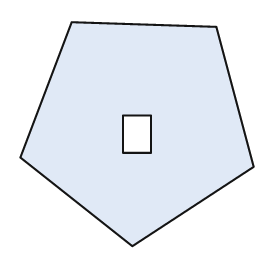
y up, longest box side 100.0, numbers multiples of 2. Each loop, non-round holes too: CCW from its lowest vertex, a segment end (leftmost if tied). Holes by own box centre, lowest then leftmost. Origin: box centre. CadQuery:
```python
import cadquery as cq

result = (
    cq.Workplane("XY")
    .moveTo(-2.0, -48.0)
    .lineTo(50.0, -14.0)
    .lineTo(34.0, 46.0)
    .lineTo(-28.0, 48.0)
    .lineTo(-50.0, -10.0)
    .close()
    .moveTo(-6.0, -8.0)
    .lineTo(6.0, -8.0)
    .lineTo(6.0, 8.0)
    .lineTo(-6.0, 8.0)
    .close()
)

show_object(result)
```